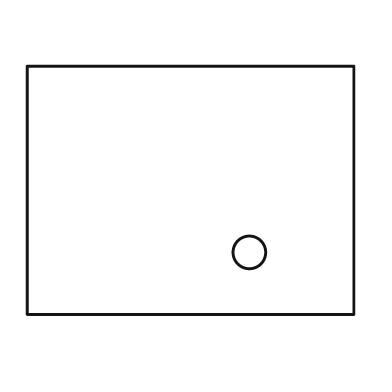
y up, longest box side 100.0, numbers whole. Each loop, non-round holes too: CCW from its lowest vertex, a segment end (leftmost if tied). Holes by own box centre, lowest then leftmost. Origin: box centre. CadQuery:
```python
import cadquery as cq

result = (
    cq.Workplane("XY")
    .moveTo(-50.0, -38.0)
    .lineTo(50.0, -38.0)
    .lineTo(50.0, 38.0)
    .lineTo(-50.0, 38.0)
    .close()
    .moveTo(18.0, -19.0)
    .circle(5.0)
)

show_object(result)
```